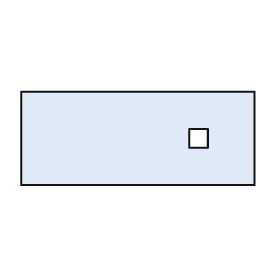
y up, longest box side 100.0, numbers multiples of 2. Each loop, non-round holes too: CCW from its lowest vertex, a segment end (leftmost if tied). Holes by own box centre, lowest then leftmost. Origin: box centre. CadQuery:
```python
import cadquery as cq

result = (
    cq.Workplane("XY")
    .moveTo(-50.0, -20.0)
    .lineTo(50.0, -20.0)
    .lineTo(50.0, 20.0)
    .lineTo(-50.0, 20.0)
    .close()
    .moveTo(22.0, -4.0)
    .lineTo(30.0, -4.0)
    .lineTo(30.0, 4.0)
    .lineTo(22.0, 4.0)
    .close()
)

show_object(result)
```